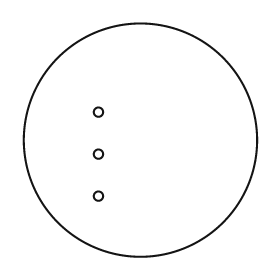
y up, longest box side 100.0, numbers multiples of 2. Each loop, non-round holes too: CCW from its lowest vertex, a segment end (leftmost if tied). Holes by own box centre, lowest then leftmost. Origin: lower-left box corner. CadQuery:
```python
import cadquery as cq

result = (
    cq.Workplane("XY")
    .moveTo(50.0, 50.0)
    .circle(50.0)
    .moveTo(32.0, 26.0)
    .circle(2.0)
    .moveTo(32.0, 44.0)
    .circle(2.0)
    .moveTo(32.0, 62.0)
    .circle(2.0)
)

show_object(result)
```